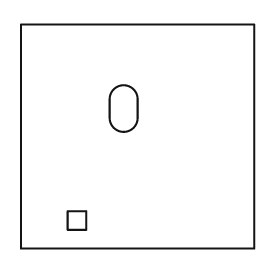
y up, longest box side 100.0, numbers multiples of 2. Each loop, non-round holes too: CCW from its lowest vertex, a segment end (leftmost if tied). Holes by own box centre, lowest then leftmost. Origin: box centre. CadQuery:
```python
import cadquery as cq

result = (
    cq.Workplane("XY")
    .moveTo(-50.0, -48.0)
    .lineTo(50.0, -48.0)
    .lineTo(50.0, 48.0)
    .lineTo(-50.0, 48.0)
    .close()
    .moveTo(-30.0, -40.0)
    .lineTo(-22.0, -40.0)
    .lineTo(-22.0, -32.0)
    .lineTo(-30.0, -32.0)
    .close()
    .moveTo(-12.0, 8.0)
    .threePointArc((-6.0, 2.0), (0.0, 8.0))
    .lineTo(0.0, 16.0)
    .threePointArc((-6.0, 22.0), (-12.0, 16.0))
    .close()
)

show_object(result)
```